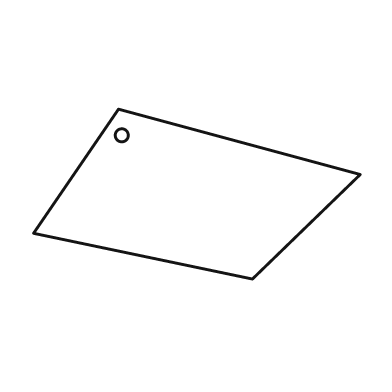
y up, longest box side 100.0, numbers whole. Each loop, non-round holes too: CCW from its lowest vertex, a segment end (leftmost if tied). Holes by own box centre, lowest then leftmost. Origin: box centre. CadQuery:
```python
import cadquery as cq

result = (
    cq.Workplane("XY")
    .moveTo(17.0, -26.0)
    .lineTo(50.0, 6.0)
    .lineTo(-24.0, 26.0)
    .lineTo(-50.0, -12.0)
    .close()
    .moveTo(-23.0, 18.0)
    .circle(2.0)
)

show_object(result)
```